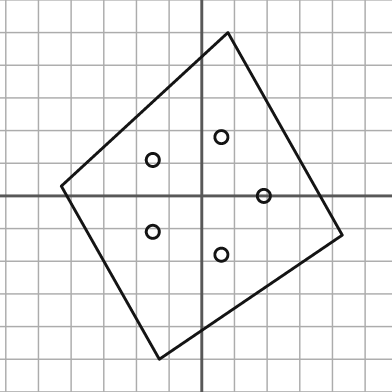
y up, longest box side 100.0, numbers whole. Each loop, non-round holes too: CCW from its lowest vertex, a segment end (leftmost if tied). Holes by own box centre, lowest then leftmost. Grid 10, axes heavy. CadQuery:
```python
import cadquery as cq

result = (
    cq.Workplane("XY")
    .moveTo(-13.0, -50.0)
    .lineTo(43.0, -12.0)
    .lineTo(8.0, 50.0)
    .lineTo(-43.0, 3.0)
    .close()
    .moveTo(6.0, -18.0)
    .circle(2.0)
    .moveTo(-15.0, -11.0)
    .circle(2.0)
    .moveTo(19.0, 0.0)
    .circle(2.0)
    .moveTo(-15.0, 11.0)
    .circle(2.0)
    .moveTo(6.0, 18.0)
    .circle(2.0)
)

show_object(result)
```